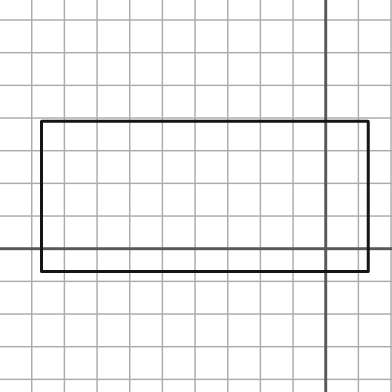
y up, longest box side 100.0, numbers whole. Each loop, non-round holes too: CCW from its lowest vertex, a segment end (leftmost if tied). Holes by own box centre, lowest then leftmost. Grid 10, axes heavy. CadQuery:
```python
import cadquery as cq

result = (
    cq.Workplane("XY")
    .moveTo(-87.0, -7.0)
    .lineTo(13.0, -7.0)
    .lineTo(13.0, 39.0)
    .lineTo(-87.0, 39.0)
    .close()
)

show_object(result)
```